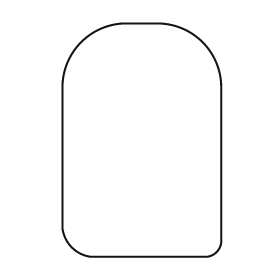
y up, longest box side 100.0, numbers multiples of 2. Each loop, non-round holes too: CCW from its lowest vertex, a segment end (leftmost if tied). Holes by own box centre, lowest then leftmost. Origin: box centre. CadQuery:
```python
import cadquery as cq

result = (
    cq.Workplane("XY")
    .moveTo(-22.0, -50.0)
    .lineTo(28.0, -50.0)
    .threePointArc((32.0, -48.0), (34.0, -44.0))
    .lineTo(34.0, 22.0)
    .threePointArc((26.0, 42.0), (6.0, 50.0))
    .lineTo(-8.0, 50.0)
    .threePointArc((-26.0, 42.0), (-34.0, 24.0))
    .lineTo(-34.0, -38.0)
    .threePointArc((-30.0, -46.0), (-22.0, -50.0))
    .close()
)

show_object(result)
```